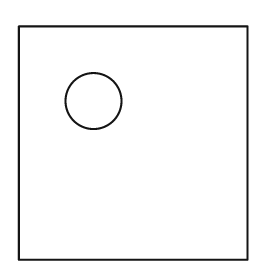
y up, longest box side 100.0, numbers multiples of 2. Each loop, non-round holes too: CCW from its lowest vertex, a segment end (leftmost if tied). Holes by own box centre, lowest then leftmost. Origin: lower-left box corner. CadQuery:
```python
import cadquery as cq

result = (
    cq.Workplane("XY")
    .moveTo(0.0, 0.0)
    .lineTo(98.0, 0.0)
    .lineTo(98.0, 100.0)
    .lineTo(0.0, 100.0)
    .close()
    .moveTo(32.0, 68.0)
    .circle(12.0)
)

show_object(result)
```